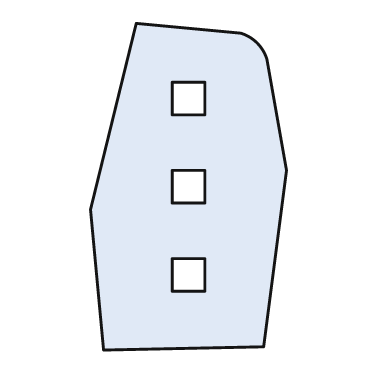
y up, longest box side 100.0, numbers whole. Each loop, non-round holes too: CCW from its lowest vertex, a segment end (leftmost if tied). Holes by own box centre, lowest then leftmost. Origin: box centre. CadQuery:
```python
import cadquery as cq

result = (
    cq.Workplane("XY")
    .moveTo(-26.0, -50.0)
    .lineTo(23.0, -49.0)
    .lineTo(30.0, 5.0)
    .lineTo(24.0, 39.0)
    .threePointArc((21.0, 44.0), (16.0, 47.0))
    .lineTo(-16.0, 50.0)
    .lineTo(-30.0, -7.0)
    .close()
    .moveTo(-5.0, -32.0)
    .lineTo(5.0, -32.0)
    .lineTo(5.0, -22.0)
    .lineTo(-5.0, -22.0)
    .close()
    .moveTo(-5.0, -5.0)
    .lineTo(5.0, -5.0)
    .lineTo(5.0, 5.0)
    .lineTo(-5.0, 5.0)
    .close()
    .moveTo(-5.0, 22.0)
    .lineTo(5.0, 22.0)
    .lineTo(5.0, 32.0)
    .lineTo(-5.0, 32.0)
    .close()
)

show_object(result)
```